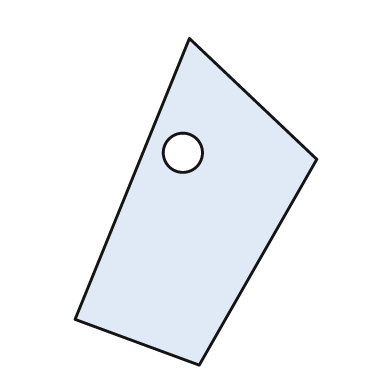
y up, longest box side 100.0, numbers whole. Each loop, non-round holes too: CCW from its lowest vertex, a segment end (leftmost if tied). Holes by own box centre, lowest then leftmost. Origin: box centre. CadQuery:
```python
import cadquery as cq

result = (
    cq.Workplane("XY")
    .moveTo(1.0, -50.0)
    .lineTo(37.0, 13.0)
    .lineTo(-2.0, 50.0)
    .lineTo(-37.0, -36.0)
    .close()
    .moveTo(-4.0, 15.0)
    .circle(6.0)
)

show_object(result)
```